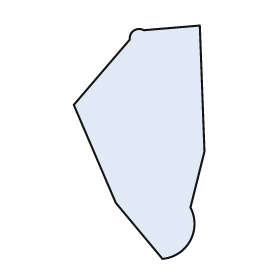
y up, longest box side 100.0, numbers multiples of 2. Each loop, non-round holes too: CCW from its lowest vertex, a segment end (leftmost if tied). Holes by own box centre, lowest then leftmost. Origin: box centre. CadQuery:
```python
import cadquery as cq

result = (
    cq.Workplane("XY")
    .moveTo(10.0, -50.0)
    .threePointArc((22.0, -42.0), (22.0, -28.0))
    .lineTo(28.0, -4.0)
    .lineTo(26.0, 50.0)
    .lineTo(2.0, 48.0)
    .threePointArc((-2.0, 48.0), (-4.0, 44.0))
    .lineTo(-28.0, 16.0)
    .lineTo(-10.0, -26.0)
    .close()
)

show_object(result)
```